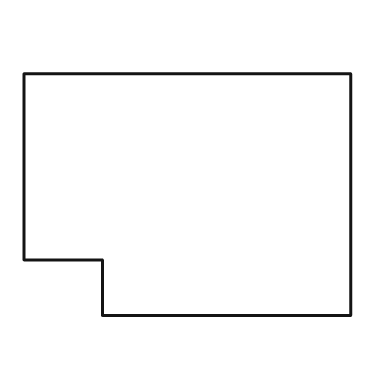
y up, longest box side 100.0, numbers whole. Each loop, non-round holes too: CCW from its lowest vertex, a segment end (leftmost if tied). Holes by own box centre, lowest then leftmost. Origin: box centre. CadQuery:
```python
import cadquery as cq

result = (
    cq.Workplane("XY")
    .moveTo(-26.0, -37.0)
    .lineTo(50.0, -37.0)
    .lineTo(50.0, 37.0)
    .lineTo(-50.0, 37.0)
    .lineTo(-50.0, -20.0)
    .lineTo(-26.0, -20.0)
    .close()
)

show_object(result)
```